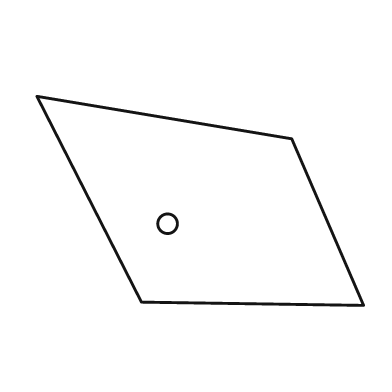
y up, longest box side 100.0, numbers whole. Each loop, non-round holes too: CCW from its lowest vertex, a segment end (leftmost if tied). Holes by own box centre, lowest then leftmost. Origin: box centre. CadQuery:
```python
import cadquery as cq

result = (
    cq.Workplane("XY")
    .moveTo(50.0, -32.0)
    .lineTo(28.0, 19.0)
    .lineTo(-50.0, 32.0)
    .lineTo(-18.0, -31.0)
    .close()
    .moveTo(-10.0, -7.0)
    .circle(3.0)
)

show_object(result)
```